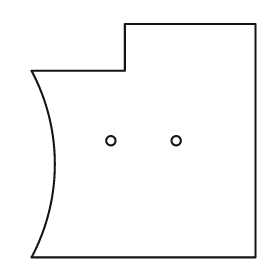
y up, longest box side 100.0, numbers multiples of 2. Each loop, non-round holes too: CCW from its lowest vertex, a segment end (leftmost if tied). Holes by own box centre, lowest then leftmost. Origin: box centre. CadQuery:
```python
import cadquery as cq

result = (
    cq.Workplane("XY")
    .moveTo(-48.0, -50.0)
    .lineTo(48.0, -50.0)
    .lineTo(48.0, 50.0)
    .lineTo(-8.0, 50.0)
    .lineTo(-8.0, 30.0)
    .lineTo(-48.0, 30.0)
    .threePointArc((-38.0, -10.0), (-48.0, -50.0))
    .close()
    .moveTo(-14.0, 0.0)
    .circle(2.0)
    .moveTo(14.0, 0.0)
    .circle(2.0)
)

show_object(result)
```